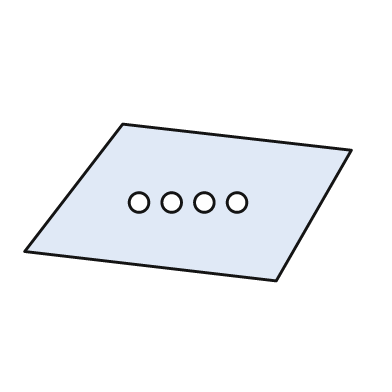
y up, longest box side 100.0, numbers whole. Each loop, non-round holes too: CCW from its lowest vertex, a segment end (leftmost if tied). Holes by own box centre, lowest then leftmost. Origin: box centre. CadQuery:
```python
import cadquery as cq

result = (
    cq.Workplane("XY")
    .moveTo(27.0, -24.0)
    .lineTo(50.0, 16.0)
    .lineTo(-20.0, 24.0)
    .lineTo(-50.0, -15.0)
    .close()
    .moveTo(-15.0, 0.0)
    .circle(3.0)
    .moveTo(-5.0, 0.0)
    .circle(3.0)
    .moveTo(5.0, 0.0)
    .circle(3.0)
    .moveTo(15.0, 0.0)
    .circle(3.0)
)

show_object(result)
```